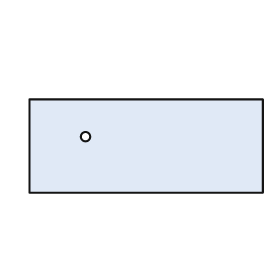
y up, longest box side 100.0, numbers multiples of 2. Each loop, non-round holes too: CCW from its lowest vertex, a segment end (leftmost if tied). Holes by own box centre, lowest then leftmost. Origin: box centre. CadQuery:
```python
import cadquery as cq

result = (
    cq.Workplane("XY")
    .moveTo(-50.0, -20.0)
    .lineTo(50.0, -20.0)
    .lineTo(50.0, 20.0)
    .lineTo(-50.0, 20.0)
    .close()
    .moveTo(-26.0, 4.0)
    .circle(2.0)
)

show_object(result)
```